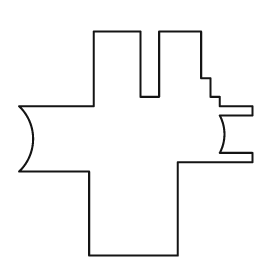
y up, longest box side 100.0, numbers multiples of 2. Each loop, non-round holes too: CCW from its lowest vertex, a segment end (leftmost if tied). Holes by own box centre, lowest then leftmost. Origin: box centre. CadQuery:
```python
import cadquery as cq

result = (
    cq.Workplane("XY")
    .moveTo(-20.0, -48.0)
    .lineTo(18.0, -48.0)
    .lineTo(18.0, -8.0)
    .lineTo(50.0, -8.0)
    .lineTo(50.0, -4.0)
    .lineTo(36.0, -4.0)
    .threePointArc((38.0, 4.0), (36.0, 12.0))
    .lineTo(50.0, 12.0)
    .lineTo(50.0, 16.0)
    .lineTo(36.0, 16.0)
    .lineTo(36.0, 20.0)
    .lineTo(32.0, 20.0)
    .lineTo(32.0, 28.0)
    .lineTo(28.0, 28.0)
    .lineTo(28.0, 48.0)
    .lineTo(10.0, 48.0)
    .lineTo(10.0, 20.0)
    .lineTo(2.0, 20.0)
    .lineTo(2.0, 48.0)
    .lineTo(-18.0, 48.0)
    .lineTo(-18.0, 16.0)
    .lineTo(-50.0, 16.0)
    .threePointArc((-44.0, 2.0), (-50.0, -12.0))
    .lineTo(-20.0, -12.0)
    .close()
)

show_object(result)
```